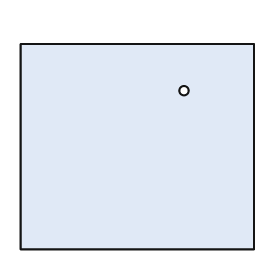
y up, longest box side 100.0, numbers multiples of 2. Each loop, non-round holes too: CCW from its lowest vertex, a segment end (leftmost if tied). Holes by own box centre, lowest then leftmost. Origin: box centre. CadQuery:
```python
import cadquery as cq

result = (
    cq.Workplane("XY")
    .moveTo(-50.0, -44.0)
    .lineTo(50.0, -44.0)
    .lineTo(50.0, 44.0)
    .lineTo(-50.0, 44.0)
    .close()
    .moveTo(20.0, 24.0)
    .circle(2.0)
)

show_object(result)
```